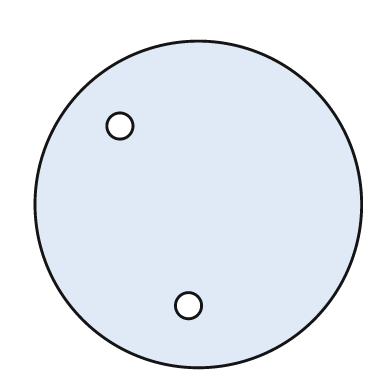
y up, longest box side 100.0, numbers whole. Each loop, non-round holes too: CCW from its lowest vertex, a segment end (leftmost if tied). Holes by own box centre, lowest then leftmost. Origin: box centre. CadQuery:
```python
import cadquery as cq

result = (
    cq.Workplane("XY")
    .moveTo(0.0, 0.0)
    .circle(50.0)
    .moveTo(-3.0, -31.0)
    .circle(4.0)
    .moveTo(-24.0, 24.0)
    .circle(4.0)
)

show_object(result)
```